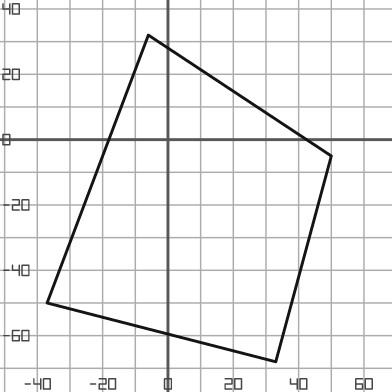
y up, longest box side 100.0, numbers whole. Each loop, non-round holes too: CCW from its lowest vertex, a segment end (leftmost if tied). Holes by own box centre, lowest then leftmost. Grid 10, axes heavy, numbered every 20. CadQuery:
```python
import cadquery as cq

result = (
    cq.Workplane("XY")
    .moveTo(33.0, -68.0)
    .lineTo(50.0, -5.0)
    .lineTo(-6.0, 32.0)
    .lineTo(-37.0, -50.0)
    .close()
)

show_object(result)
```